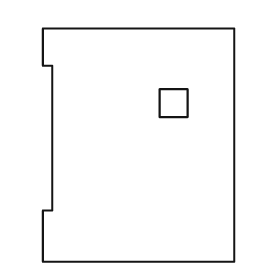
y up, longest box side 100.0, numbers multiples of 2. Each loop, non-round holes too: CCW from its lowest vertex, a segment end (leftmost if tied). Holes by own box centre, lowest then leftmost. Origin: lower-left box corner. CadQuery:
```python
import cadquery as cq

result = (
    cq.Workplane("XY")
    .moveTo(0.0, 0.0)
    .lineTo(82.0, 0.0)
    .lineTo(82.0, 100.0)
    .lineTo(0.0, 100.0)
    .lineTo(0.0, 84.0)
    .lineTo(4.0, 84.0)
    .lineTo(4.0, 22.0)
    .lineTo(0.0, 22.0)
    .close()
    .moveTo(50.0, 62.0)
    .lineTo(62.0, 62.0)
    .lineTo(62.0, 74.0)
    .lineTo(50.0, 74.0)
    .close()
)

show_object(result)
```